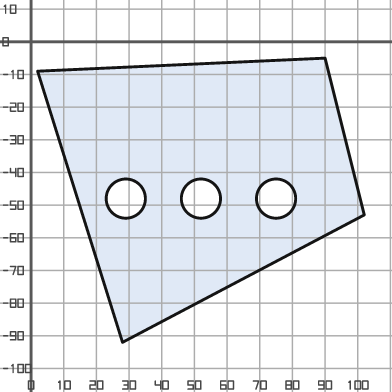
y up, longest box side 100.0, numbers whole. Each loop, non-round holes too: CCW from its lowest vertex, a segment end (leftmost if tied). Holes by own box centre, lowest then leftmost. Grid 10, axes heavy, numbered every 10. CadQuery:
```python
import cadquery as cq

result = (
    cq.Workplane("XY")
    .moveTo(28.0, -92.0)
    .lineTo(102.0, -53.0)
    .lineTo(90.0, -5.0)
    .lineTo(2.0, -9.0)
    .close()
    .moveTo(29.0, -48.0)
    .circle(6.0)
    .moveTo(52.0, -48.0)
    .circle(6.0)
    .moveTo(75.0, -48.0)
    .circle(6.0)
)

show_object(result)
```